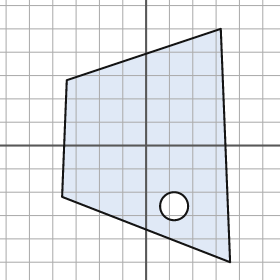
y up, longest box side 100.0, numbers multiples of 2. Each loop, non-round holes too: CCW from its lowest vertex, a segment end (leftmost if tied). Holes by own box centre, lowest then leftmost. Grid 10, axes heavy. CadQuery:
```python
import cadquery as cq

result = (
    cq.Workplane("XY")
    .moveTo(36.0, -50.0)
    .lineTo(32.0, 50.0)
    .lineTo(-34.0, 28.0)
    .lineTo(-36.0, -22.0)
    .close()
    .moveTo(12.0, -26.0)
    .circle(6.0)
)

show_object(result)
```